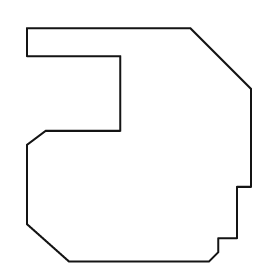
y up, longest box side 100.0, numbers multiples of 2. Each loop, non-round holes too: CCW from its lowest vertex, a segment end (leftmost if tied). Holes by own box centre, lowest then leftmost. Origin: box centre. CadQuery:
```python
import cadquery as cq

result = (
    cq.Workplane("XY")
    .moveTo(-30.0, -50.0)
    .lineTo(30.0, -50.0)
    .lineTo(34.0, -46.0)
    .lineTo(34.0, -40.0)
    .lineTo(42.0, -40.0)
    .lineTo(42.0, -18.0)
    .lineTo(48.0, -18.0)
    .lineTo(48.0, 24.0)
    .lineTo(22.0, 50.0)
    .lineTo(-48.0, 50.0)
    .lineTo(-48.0, 38.0)
    .lineTo(-8.0, 38.0)
    .lineTo(-8.0, 6.0)
    .lineTo(-40.0, 6.0)
    .lineTo(-48.0, 0.0)
    .lineTo(-48.0, -34.0)
    .close()
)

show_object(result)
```